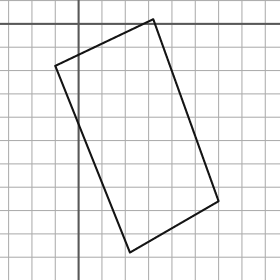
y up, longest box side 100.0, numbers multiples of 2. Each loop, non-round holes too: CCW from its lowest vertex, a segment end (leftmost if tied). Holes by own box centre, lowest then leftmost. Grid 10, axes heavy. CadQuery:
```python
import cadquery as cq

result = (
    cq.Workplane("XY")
    .moveTo(22.0, -98.0)
    .lineTo(60.0, -76.0)
    .lineTo(32.0, 2.0)
    .lineTo(-10.0, -18.0)
    .close()
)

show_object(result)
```